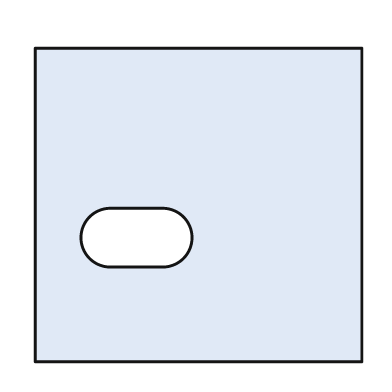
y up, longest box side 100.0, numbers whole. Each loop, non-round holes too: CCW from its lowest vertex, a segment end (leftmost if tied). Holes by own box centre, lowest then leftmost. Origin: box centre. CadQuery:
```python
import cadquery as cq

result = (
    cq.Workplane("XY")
    .moveTo(-50.0, -48.0)
    .lineTo(50.0, -48.0)
    .lineTo(50.0, 48.0)
    .lineTo(-50.0, 48.0)
    .close()
    .moveTo(-27.0, -19.0)
    .lineTo(-11.0, -19.0)
    .threePointArc((-2.0, -10.0), (-11.0, -1.0))
    .lineTo(-27.0, -1.0)
    .threePointArc((-36.0, -10.0), (-27.0, -19.0))
    .close()
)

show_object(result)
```